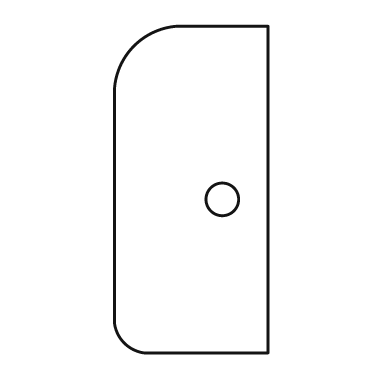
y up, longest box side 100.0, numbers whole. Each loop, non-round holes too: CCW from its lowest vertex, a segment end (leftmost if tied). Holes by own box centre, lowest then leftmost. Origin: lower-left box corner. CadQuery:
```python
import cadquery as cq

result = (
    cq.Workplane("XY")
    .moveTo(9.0, 0.0)
    .lineTo(47.0, 0.0)
    .lineTo(47.0, 100.0)
    .lineTo(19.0, 100.0)
    .threePointArc((6.0, 94.0), (0.0, 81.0))
    .lineTo(0.0, 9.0)
    .threePointArc((3.0, 3.0), (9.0, 0.0))
    .close()
    .moveTo(33.0, 47.0)
    .circle(5.0)
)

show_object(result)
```